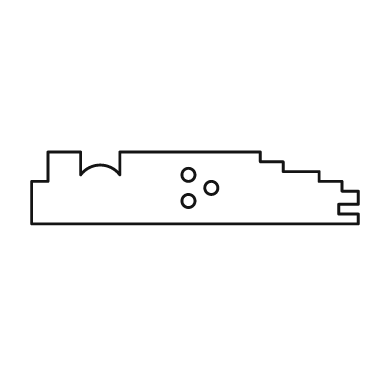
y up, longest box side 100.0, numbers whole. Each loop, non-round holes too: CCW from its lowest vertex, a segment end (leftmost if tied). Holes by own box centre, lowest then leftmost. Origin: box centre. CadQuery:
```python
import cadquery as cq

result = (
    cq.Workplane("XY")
    .moveTo(-50.0, -11.0)
    .lineTo(50.0, -11.0)
    .lineTo(50.0, -8.0)
    .lineTo(44.0, -8.0)
    .lineTo(44.0, -5.0)
    .lineTo(50.0, -5.0)
    .lineTo(50.0, -1.0)
    .lineTo(45.0, -1.0)
    .lineTo(45.0, 2.0)
    .lineTo(38.0, 2.0)
    .lineTo(38.0, 5.0)
    .lineTo(27.0, 5.0)
    .lineTo(27.0, 8.0)
    .lineTo(20.0, 8.0)
    .lineTo(20.0, 11.0)
    .lineTo(-23.0, 11.0)
    .lineTo(-23.0, 4.0)
    .threePointArc((-29.0, 7.0), (-35.0, 4.0))
    .lineTo(-35.0, 11.0)
    .lineTo(-45.0, 11.0)
    .lineTo(-45.0, 2.0)
    .lineTo(-50.0, 2.0)
    .close()
    .moveTo(-2.0, -4.0)
    .circle(2.0)
    .moveTo(5.0, 0.0)
    .circle(2.0)
    .moveTo(-2.0, 4.0)
    .circle(2.0)
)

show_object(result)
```